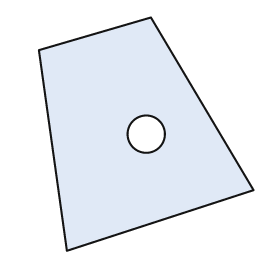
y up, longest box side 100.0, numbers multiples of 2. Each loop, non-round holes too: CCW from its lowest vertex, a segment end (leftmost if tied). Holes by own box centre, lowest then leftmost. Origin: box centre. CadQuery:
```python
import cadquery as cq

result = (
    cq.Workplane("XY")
    .moveTo(-34.0, -50.0)
    .lineTo(46.0, -24.0)
    .lineTo(2.0, 50.0)
    .lineTo(-46.0, 36.0)
    .close()
    .moveTo(0.0, 0.0)
    .circle(8.0)
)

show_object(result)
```